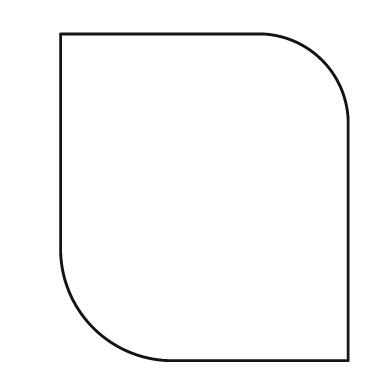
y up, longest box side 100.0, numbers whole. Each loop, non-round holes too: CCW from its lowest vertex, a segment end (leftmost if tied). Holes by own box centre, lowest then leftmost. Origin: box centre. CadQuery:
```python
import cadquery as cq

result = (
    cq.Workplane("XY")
    .moveTo(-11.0, -50.0)
    .lineTo(44.0, -50.0)
    .lineTo(44.0, 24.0)
    .threePointArc((36.0, 42.0), (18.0, 50.0))
    .lineTo(-44.0, 50.0)
    .lineTo(-44.0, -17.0)
    .threePointArc((-34.0, -40.0), (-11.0, -50.0))
    .close()
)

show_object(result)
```